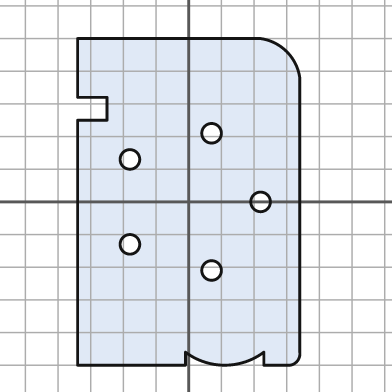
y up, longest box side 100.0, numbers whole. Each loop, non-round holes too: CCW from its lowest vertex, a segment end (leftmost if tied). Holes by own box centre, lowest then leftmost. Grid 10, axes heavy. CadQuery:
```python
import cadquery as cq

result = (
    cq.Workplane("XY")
    .moveTo(-34.0, -50.0)
    .lineTo(-1.0, -50.0)
    .lineTo(-1.0, -46.0)
    .threePointArc((11.0, -50.0), (23.0, -46.0))
    .lineTo(23.0, -50.0)
    .lineTo(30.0, -50.0)
    .threePointArc((33.0, -49.0), (34.0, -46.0))
    .lineTo(34.0, 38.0)
    .threePointArc((30.0, 46.0), (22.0, 50.0))
    .lineTo(-34.0, 50.0)
    .lineTo(-34.0, 32.0)
    .lineTo(-25.0, 32.0)
    .lineTo(-25.0, 25.0)
    .lineTo(-34.0, 25.0)
    .close()
    .moveTo(7.0, -21.0)
    .circle(3.0)
    .moveTo(-18.0, -13.0)
    .circle(3.0)
    .moveTo(22.0, 0.0)
    .circle(3.0)
    .moveTo(-18.0, 13.0)
    .circle(3.0)
    .moveTo(7.0, 21.0)
    .circle(3.0)
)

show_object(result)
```